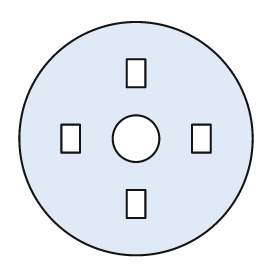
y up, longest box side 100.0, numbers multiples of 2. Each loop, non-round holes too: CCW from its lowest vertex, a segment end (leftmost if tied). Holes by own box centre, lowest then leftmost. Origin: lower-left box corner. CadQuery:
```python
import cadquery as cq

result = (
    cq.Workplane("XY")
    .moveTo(50.0, 50.0)
    .circle(50.0)
    .moveTo(46.0, 16.0)
    .lineTo(54.0, 16.0)
    .lineTo(54.0, 28.0)
    .lineTo(46.0, 28.0)
    .close()
    .moveTo(18.0, 44.0)
    .lineTo(26.0, 44.0)
    .lineTo(26.0, 56.0)
    .lineTo(18.0, 56.0)
    .close()
    .moveTo(50.0, 50.0)
    .circle(10.0)
    .moveTo(74.0, 44.0)
    .lineTo(82.0, 44.0)
    .lineTo(82.0, 56.0)
    .lineTo(74.0, 56.0)
    .close()
    .moveTo(46.0, 72.0)
    .lineTo(54.0, 72.0)
    .lineTo(54.0, 84.0)
    .lineTo(46.0, 84.0)
    .close()
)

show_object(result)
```